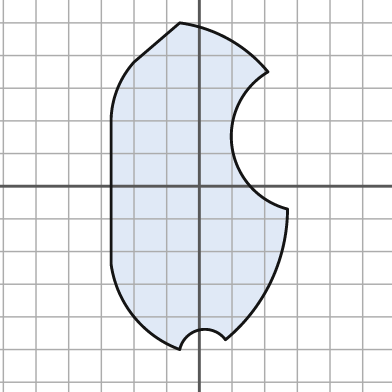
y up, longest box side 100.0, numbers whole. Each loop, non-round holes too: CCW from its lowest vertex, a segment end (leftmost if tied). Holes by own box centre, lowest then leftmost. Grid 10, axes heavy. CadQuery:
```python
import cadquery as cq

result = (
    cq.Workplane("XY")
    .moveTo(-6.0, -50.0)
    .threePointArc((0.0, -44.0), (8.0, -47.0))
    .threePointArc((22.0, -29.0), (27.0, -7.0))
    .threePointArc((10.0, 12.0), (21.0, 35.0))
    .threePointArc((9.0, 45.0), (-6.0, 50.0))
    .lineTo(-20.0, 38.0)
    .threePointArc((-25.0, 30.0), (-27.0, 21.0))
    .lineTo(-27.0, -24.0)
    .threePointArc((-20.0, -40.0), (-6.0, -50.0))
    .close()
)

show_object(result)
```